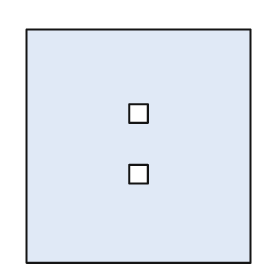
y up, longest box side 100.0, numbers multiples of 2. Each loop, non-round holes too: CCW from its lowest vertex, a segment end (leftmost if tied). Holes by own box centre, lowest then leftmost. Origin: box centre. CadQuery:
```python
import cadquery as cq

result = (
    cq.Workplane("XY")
    .moveTo(-48.0, -50.0)
    .lineTo(48.0, -50.0)
    .lineTo(48.0, 50.0)
    .lineTo(-48.0, 50.0)
    .close()
    .moveTo(-4.0, -16.0)
    .lineTo(4.0, -16.0)
    .lineTo(4.0, -8.0)
    .lineTo(-4.0, -8.0)
    .close()
    .moveTo(-4.0, 10.0)
    .lineTo(4.0, 10.0)
    .lineTo(4.0, 18.0)
    .lineTo(-4.0, 18.0)
    .close()
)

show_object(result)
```